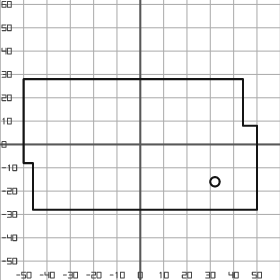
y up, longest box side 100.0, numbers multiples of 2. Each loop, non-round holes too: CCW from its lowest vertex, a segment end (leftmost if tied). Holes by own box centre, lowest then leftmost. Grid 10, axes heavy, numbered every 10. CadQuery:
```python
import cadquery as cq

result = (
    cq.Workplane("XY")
    .moveTo(-46.0, -28.0)
    .lineTo(50.0, -28.0)
    .lineTo(50.0, 8.0)
    .lineTo(44.0, 8.0)
    .lineTo(44.0, 28.0)
    .lineTo(-50.0, 28.0)
    .lineTo(-50.0, -8.0)
    .lineTo(-46.0, -8.0)
    .close()
    .moveTo(32.0, -16.0)
    .circle(2.0)
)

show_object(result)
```